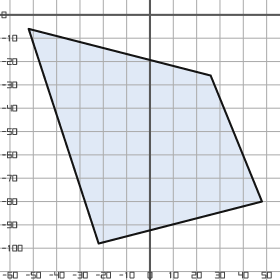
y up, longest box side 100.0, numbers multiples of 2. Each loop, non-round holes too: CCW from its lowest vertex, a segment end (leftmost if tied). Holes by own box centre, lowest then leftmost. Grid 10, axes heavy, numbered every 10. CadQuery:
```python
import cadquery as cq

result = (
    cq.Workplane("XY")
    .moveTo(-22.0, -98.0)
    .lineTo(48.0, -80.0)
    .lineTo(26.0, -26.0)
    .lineTo(-52.0, -6.0)
    .close()
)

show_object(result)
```